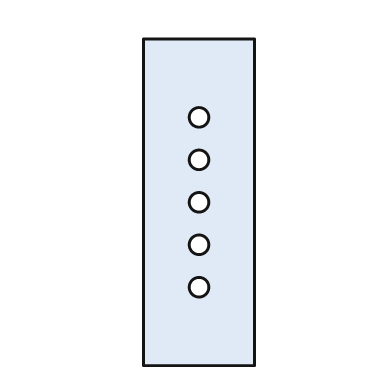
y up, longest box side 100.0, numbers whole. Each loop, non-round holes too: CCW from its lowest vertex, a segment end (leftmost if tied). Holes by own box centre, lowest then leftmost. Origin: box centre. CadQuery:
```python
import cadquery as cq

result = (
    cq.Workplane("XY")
    .moveTo(-17.0, -50.0)
    .lineTo(17.0, -50.0)
    .lineTo(17.0, 50.0)
    .lineTo(-17.0, 50.0)
    .close()
    .moveTo(0.0, -26.0)
    .circle(3.0)
    .moveTo(0.0, -13.0)
    .circle(3.0)
    .moveTo(0.0, 0.0)
    .circle(3.0)
    .moveTo(0.0, 13.0)
    .circle(3.0)
    .moveTo(0.0, 26.0)
    .circle(3.0)
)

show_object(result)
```